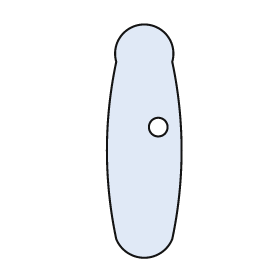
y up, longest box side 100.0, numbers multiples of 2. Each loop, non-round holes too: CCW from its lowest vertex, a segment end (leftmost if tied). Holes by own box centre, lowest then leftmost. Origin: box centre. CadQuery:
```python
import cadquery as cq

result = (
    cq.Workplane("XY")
    .moveTo(-12.0, -42.0)
    .threePointArc((0.0, -50.0), (12.0, -42.0))
    .threePointArc((16.0, -4.0), (12.0, 34.0))
    .threePointArc((0.0, 50.0), (-12.0, 34.0))
    .threePointArc((-16.0, -4.0), (-12.0, -42.0))
    .close()
    .moveTo(6.0, 6.0)
    .circle(4.0)
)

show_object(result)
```